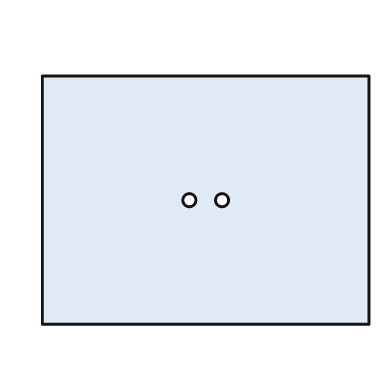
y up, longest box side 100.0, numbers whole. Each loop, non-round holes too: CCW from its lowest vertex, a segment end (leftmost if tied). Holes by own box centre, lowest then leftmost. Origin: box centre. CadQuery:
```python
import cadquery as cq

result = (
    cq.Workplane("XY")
    .moveTo(-50.0, -38.0)
    .lineTo(50.0, -38.0)
    .lineTo(50.0, 38.0)
    .lineTo(-50.0, 38.0)
    .close()
    .moveTo(-5.0, 0.0)
    .circle(2.0)
    .moveTo(5.0, 0.0)
    .circle(2.0)
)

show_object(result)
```